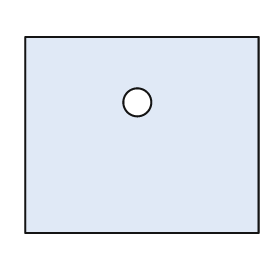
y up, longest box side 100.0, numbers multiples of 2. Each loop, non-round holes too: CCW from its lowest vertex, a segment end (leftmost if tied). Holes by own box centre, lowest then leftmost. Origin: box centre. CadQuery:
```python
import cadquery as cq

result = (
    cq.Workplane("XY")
    .moveTo(-50.0, -42.0)
    .lineTo(50.0, -42.0)
    .lineTo(50.0, 42.0)
    .lineTo(-50.0, 42.0)
    .close()
    .moveTo(-2.0, 14.0)
    .circle(6.0)
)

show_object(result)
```